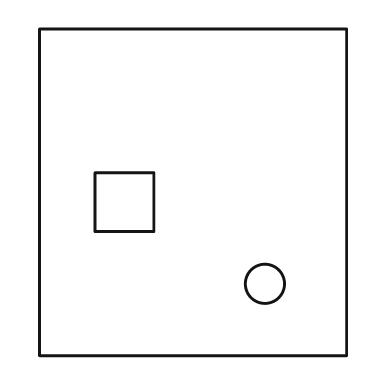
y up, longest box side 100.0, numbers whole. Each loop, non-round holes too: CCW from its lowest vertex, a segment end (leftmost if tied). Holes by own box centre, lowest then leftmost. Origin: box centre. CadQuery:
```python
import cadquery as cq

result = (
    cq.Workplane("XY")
    .moveTo(-47.0, -50.0)
    .lineTo(47.0, -50.0)
    .lineTo(47.0, 50.0)
    .lineTo(-47.0, 50.0)
    .close()
    .moveTo(22.0, -28.0)
    .circle(6.0)
    .moveTo(-30.0, -12.0)
    .lineTo(-12.0, -12.0)
    .lineTo(-12.0, 6.0)
    .lineTo(-30.0, 6.0)
    .close()
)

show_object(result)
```